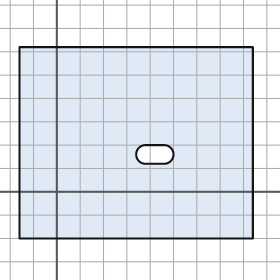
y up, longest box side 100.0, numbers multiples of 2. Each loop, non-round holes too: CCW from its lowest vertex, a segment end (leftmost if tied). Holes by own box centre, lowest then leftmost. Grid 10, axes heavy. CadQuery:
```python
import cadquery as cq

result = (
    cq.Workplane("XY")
    .moveTo(-16.0, -20.0)
    .lineTo(84.0, -20.0)
    .lineTo(84.0, 62.0)
    .lineTo(-16.0, 62.0)
    .close()
    .moveTo(38.0, 12.0)
    .lineTo(46.0, 12.0)
    .threePointArc((50.0, 16.0), (46.0, 20.0))
    .lineTo(38.0, 20.0)
    .threePointArc((34.0, 16.0), (38.0, 12.0))
    .close()
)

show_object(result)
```